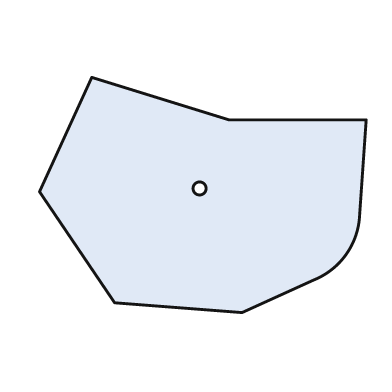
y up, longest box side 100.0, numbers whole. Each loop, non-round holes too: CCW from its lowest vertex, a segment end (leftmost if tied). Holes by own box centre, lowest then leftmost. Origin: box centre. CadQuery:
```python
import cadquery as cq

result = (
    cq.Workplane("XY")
    .moveTo(12.0, -36.0)
    .lineTo(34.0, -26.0)
    .threePointArc((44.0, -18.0), (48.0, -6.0))
    .lineTo(50.0, 23.0)
    .lineTo(8.0, 23.0)
    .lineTo(-34.0, 36.0)
    .lineTo(-50.0, 1.0)
    .lineTo(-27.0, -33.0)
    .close()
    .moveTo(-1.0, 2.0)
    .circle(2.0)
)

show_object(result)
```